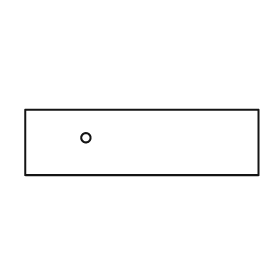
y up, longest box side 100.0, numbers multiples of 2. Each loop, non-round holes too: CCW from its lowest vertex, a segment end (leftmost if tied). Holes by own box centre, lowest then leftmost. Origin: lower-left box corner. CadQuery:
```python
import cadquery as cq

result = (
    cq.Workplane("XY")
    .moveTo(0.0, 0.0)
    .lineTo(100.0, 0.0)
    .lineTo(100.0, 28.0)
    .lineTo(0.0, 28.0)
    .close()
    .moveTo(26.0, 16.0)
    .circle(2.0)
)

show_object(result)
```